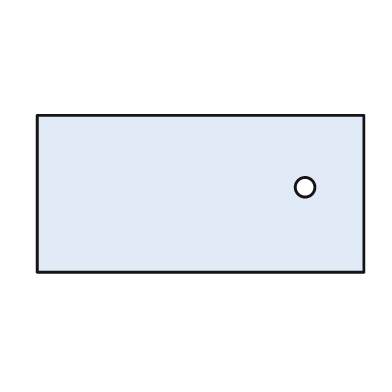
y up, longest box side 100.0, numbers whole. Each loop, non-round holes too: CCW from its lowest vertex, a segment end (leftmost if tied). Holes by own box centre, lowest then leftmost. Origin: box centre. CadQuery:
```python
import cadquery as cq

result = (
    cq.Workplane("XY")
    .moveTo(-50.0, -24.0)
    .lineTo(50.0, -24.0)
    .lineTo(50.0, 24.0)
    .lineTo(-50.0, 24.0)
    .close()
    .moveTo(32.0, 2.0)
    .circle(3.0)
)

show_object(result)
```